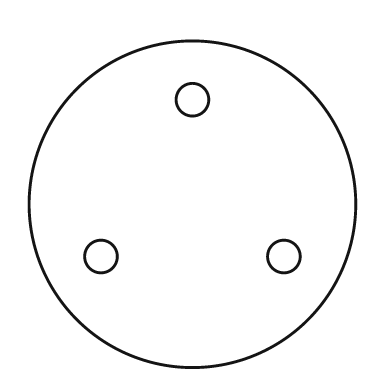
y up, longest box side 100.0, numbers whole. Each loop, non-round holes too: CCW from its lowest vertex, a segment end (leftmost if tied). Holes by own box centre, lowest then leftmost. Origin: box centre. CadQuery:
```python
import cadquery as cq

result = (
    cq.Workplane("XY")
    .moveTo(0.0, 0.0)
    .circle(50.0)
    .moveTo(-28.0, -16.0)
    .circle(5.0)
    .moveTo(28.0, -16.0)
    .circle(5.0)
    .moveTo(0.0, 32.0)
    .circle(5.0)
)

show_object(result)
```